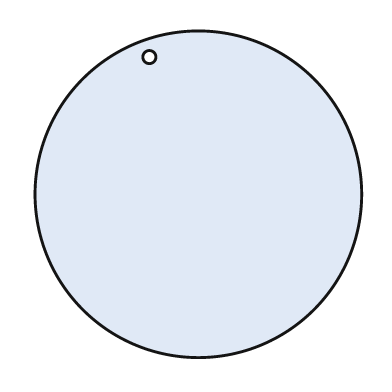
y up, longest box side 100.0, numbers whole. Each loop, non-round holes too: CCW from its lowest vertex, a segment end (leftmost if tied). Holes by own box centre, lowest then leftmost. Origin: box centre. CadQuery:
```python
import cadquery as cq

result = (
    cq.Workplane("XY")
    .moveTo(0.0, 0.0)
    .circle(50.0)
    .moveTo(-15.0, 42.0)
    .circle(2.0)
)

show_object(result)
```